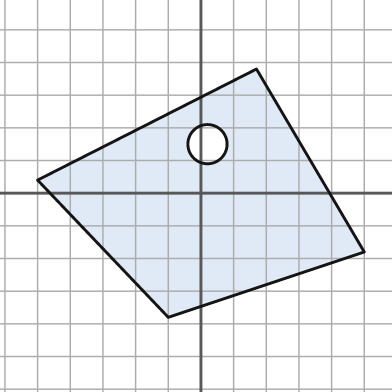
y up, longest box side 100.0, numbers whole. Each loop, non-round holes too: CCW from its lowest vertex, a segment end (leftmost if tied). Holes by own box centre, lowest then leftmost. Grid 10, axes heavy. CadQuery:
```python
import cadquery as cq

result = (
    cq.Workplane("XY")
    .moveTo(-10.0, -38.0)
    .lineTo(50.0, -18.0)
    .lineTo(17.0, 38.0)
    .lineTo(-50.0, 4.0)
    .close()
    .moveTo(2.0, 15.0)
    .circle(6.0)
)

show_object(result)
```